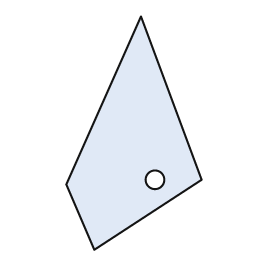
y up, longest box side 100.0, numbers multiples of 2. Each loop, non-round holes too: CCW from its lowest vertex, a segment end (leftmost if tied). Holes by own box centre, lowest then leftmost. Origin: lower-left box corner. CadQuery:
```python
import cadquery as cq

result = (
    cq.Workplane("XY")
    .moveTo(12.0, 0.0)
    .lineTo(58.0, 30.0)
    .lineTo(32.0, 100.0)
    .lineTo(0.0, 28.0)
    .close()
    .moveTo(38.0, 30.0)
    .circle(4.0)
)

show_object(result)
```